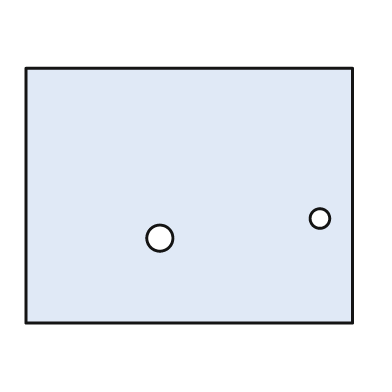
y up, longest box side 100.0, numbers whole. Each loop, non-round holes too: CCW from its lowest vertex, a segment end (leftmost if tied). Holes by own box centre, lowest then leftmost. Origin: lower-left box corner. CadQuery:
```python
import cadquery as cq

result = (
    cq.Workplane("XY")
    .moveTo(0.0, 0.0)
    .lineTo(100.0, 0.0)
    .lineTo(100.0, 78.0)
    .lineTo(0.0, 78.0)
    .close()
    .moveTo(41.0, 26.0)
    .circle(4.0)
    .moveTo(90.0, 32.0)
    .circle(3.0)
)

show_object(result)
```